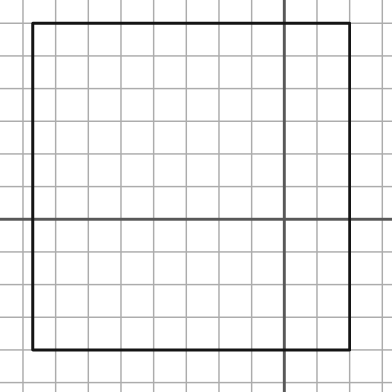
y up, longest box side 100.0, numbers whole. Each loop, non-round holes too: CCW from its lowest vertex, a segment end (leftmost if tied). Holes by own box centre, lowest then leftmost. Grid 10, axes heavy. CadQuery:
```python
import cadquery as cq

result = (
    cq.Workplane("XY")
    .moveTo(-77.0, -40.0)
    .lineTo(20.0, -40.0)
    .lineTo(20.0, 60.0)
    .lineTo(-77.0, 60.0)
    .close()
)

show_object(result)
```